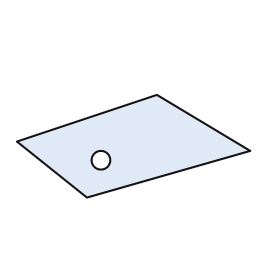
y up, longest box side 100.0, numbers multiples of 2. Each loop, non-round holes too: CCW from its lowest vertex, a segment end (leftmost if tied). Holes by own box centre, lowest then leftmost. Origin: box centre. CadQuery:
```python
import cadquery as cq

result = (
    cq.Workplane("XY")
    .moveTo(-20.0, -22.0)
    .lineTo(50.0, -2.0)
    .lineTo(10.0, 22.0)
    .lineTo(-50.0, 2.0)
    .close()
    .moveTo(-14.0, -6.0)
    .circle(4.0)
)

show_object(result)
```